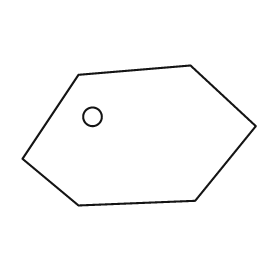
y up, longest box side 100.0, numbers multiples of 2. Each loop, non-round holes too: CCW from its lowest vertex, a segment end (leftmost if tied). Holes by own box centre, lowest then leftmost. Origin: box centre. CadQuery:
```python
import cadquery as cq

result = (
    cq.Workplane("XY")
    .moveTo(-26.0, -30.0)
    .lineTo(24.0, -28.0)
    .lineTo(50.0, 4.0)
    .lineTo(22.0, 30.0)
    .lineTo(-26.0, 26.0)
    .lineTo(-50.0, -10.0)
    .close()
    .moveTo(-20.0, 8.0)
    .circle(4.0)
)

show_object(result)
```